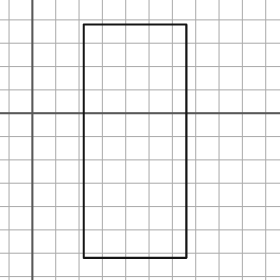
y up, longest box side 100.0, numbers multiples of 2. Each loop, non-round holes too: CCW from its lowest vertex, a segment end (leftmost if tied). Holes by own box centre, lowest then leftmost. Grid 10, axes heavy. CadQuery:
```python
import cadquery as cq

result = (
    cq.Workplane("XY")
    .moveTo(22.0, -62.0)
    .lineTo(66.0, -62.0)
    .lineTo(66.0, 38.0)
    .lineTo(22.0, 38.0)
    .close()
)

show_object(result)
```